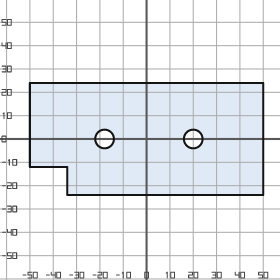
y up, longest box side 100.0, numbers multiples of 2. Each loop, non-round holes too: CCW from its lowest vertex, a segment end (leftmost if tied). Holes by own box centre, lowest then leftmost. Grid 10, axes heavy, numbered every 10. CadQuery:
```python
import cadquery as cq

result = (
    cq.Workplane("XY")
    .moveTo(-34.0, -24.0)
    .lineTo(50.0, -24.0)
    .lineTo(50.0, 24.0)
    .lineTo(-50.0, 24.0)
    .lineTo(-50.0, -12.0)
    .lineTo(-34.0, -12.0)
    .close()
    .moveTo(-18.0, 0.0)
    .circle(4.0)
    .moveTo(20.0, 0.0)
    .circle(4.0)
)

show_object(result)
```